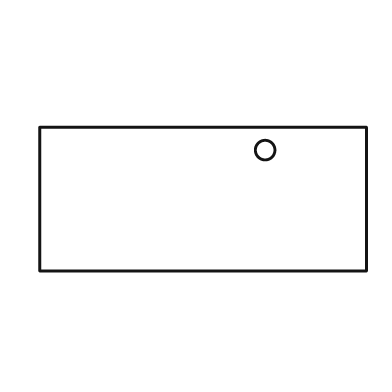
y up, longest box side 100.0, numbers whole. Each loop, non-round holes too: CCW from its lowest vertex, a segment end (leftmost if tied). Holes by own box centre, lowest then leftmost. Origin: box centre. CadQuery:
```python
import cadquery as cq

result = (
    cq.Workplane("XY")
    .moveTo(-50.0, -22.0)
    .lineTo(50.0, -22.0)
    .lineTo(50.0, 22.0)
    .lineTo(-50.0, 22.0)
    .close()
    .moveTo(19.0, 15.0)
    .circle(3.0)
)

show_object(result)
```